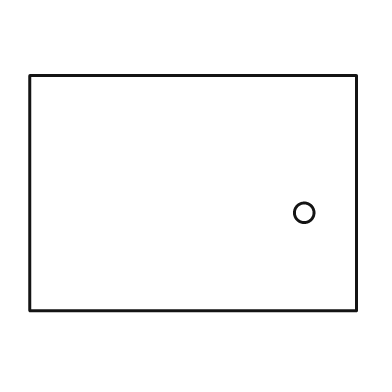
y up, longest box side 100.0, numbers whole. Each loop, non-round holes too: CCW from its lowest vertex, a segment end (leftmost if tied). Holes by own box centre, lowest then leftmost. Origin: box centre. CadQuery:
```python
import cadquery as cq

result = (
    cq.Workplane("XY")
    .moveTo(-50.0, -36.0)
    .lineTo(50.0, -36.0)
    .lineTo(50.0, 36.0)
    .lineTo(-50.0, 36.0)
    .close()
    .moveTo(34.0, -6.0)
    .circle(3.0)
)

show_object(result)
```